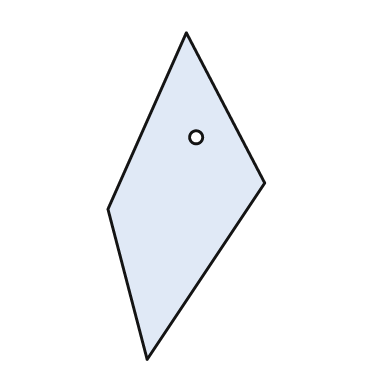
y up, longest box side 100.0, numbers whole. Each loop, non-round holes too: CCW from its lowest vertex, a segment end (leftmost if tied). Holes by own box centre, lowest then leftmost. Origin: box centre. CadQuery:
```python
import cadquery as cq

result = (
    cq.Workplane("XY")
    .moveTo(-12.0, -50.0)
    .lineTo(24.0, 4.0)
    .lineTo(0.0, 50.0)
    .lineTo(-24.0, -4.0)
    .close()
    .moveTo(3.0, 18.0)
    .circle(2.0)
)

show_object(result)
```